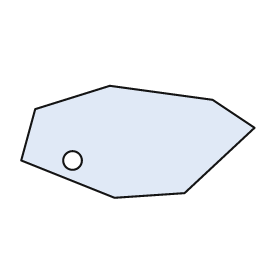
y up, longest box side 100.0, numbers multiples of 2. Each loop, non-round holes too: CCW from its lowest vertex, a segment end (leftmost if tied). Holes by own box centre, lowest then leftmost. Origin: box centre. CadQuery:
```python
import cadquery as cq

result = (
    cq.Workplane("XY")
    .moveTo(-10.0, -24.0)
    .lineTo(20.0, -22.0)
    .lineTo(50.0, 6.0)
    .lineTo(32.0, 18.0)
    .lineTo(-12.0, 24.0)
    .lineTo(-44.0, 14.0)
    .lineTo(-50.0, -8.0)
    .close()
    .moveTo(-28.0, -8.0)
    .circle(4.0)
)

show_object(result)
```